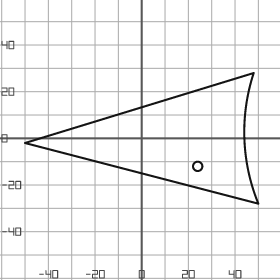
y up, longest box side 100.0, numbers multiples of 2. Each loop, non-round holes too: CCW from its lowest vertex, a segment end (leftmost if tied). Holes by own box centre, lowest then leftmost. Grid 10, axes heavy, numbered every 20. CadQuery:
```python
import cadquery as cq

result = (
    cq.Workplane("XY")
    .moveTo(50.0, -28.0)
    .threePointArc((44.0, 0.0), (48.0, 28.0))
    .lineTo(-50.0, -2.0)
    .close()
    .moveTo(24.0, -12.0)
    .circle(2.0)
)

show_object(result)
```